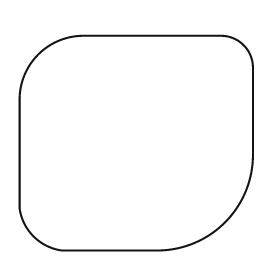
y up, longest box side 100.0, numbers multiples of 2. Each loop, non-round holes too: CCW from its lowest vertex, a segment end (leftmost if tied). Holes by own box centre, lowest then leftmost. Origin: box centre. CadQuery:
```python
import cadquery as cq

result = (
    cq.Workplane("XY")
    .moveTo(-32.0, -46.0)
    .lineTo(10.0, -46.0)
    .threePointArc((38.0, -34.0), (50.0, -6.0))
    .lineTo(50.0, 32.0)
    .threePointArc((46.0, 42.0), (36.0, 46.0))
    .lineTo(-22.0, 46.0)
    .threePointArc((-42.0, 38.0), (-50.0, 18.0))
    .lineTo(-50.0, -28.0)
    .threePointArc((-44.0, -40.0), (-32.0, -46.0))
    .close()
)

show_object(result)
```